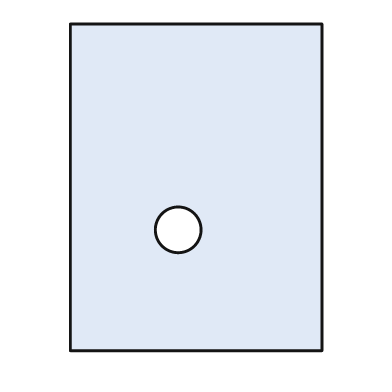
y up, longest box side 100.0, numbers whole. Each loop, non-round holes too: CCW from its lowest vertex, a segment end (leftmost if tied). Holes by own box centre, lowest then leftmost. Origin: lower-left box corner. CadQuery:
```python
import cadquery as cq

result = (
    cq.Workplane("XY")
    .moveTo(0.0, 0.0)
    .lineTo(77.0, 0.0)
    .lineTo(77.0, 100.0)
    .lineTo(0.0, 100.0)
    .close()
    .moveTo(33.0, 37.0)
    .circle(7.0)
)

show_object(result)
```